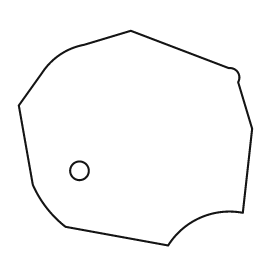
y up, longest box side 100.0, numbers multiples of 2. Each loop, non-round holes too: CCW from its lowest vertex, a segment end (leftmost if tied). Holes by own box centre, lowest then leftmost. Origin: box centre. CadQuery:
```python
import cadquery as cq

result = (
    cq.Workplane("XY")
    .moveTo(14.0, -46.0)
    .threePointArc((28.0, -34.0), (46.0, -32.0))
    .lineTo(50.0, 4.0)
    .lineTo(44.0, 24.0)
    .threePointArc((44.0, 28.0), (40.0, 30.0))
    .lineTo(-2.0, 46.0)
    .lineTo(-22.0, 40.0)
    .threePointArc((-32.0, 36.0), (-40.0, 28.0))
    .lineTo(-50.0, 14.0)
    .lineTo(-44.0, -20.0)
    .threePointArc((-38.0, -30.0), (-30.0, -38.0))
    .close()
    .moveTo(-24.0, -14.0)
    .circle(4.0)
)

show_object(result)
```